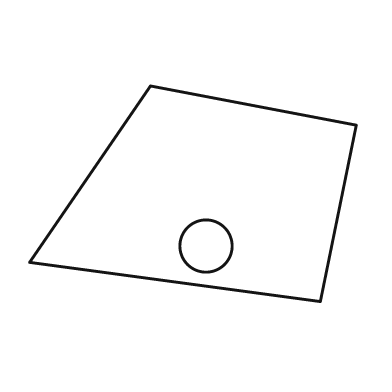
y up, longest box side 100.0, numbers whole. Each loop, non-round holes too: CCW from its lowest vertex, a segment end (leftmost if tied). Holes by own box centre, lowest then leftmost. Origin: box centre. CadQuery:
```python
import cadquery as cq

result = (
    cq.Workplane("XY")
    .moveTo(39.0, -33.0)
    .lineTo(50.0, 21.0)
    .lineTo(-13.0, 33.0)
    .lineTo(-50.0, -21.0)
    .close()
    .moveTo(4.0, -16.0)
    .circle(8.0)
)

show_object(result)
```